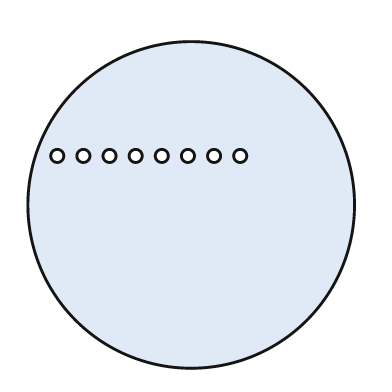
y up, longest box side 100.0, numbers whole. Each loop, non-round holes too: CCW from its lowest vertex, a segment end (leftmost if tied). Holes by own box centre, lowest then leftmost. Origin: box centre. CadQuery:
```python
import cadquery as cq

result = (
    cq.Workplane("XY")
    .moveTo(0.0, 0.0)
    .circle(50.0)
    .moveTo(-41.0, 15.0)
    .circle(2.0)
    .moveTo(-33.0, 15.0)
    .circle(2.0)
    .moveTo(-25.0, 15.0)
    .circle(2.0)
    .moveTo(-17.0, 15.0)
    .circle(2.0)
    .moveTo(-9.0, 15.0)
    .circle(2.0)
    .moveTo(-1.0, 15.0)
    .circle(2.0)
    .moveTo(7.0, 15.0)
    .circle(2.0)
    .moveTo(15.0, 15.0)
    .circle(2.0)
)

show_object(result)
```